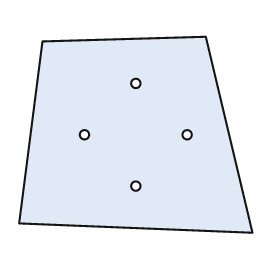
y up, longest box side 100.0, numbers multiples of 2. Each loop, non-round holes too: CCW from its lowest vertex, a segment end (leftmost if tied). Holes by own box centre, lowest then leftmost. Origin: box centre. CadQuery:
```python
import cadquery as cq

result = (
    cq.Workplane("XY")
    .moveTo(50.0, -42.0)
    .lineTo(30.0, 42.0)
    .lineTo(-40.0, 40.0)
    .lineTo(-50.0, -38.0)
    .close()
    .moveTo(0.0, -22.0)
    .circle(2.0)
    .moveTo(-22.0, 0.0)
    .circle(2.0)
    .moveTo(22.0, 0.0)
    .circle(2.0)
    .moveTo(0.0, 22.0)
    .circle(2.0)
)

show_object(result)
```